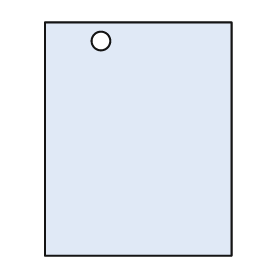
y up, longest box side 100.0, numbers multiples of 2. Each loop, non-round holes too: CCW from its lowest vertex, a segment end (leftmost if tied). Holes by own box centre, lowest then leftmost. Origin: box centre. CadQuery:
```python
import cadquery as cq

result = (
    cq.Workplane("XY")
    .moveTo(-40.0, -50.0)
    .lineTo(40.0, -50.0)
    .lineTo(40.0, 50.0)
    .lineTo(-40.0, 50.0)
    .close()
    .moveTo(-16.0, 42.0)
    .circle(4.0)
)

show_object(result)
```